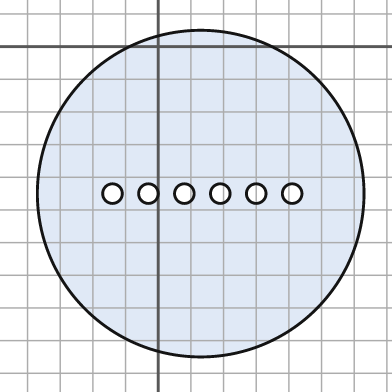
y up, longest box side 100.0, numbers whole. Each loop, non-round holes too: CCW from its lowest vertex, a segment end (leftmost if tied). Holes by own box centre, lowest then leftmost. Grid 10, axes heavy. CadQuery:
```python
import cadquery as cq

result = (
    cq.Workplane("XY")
    .moveTo(13.0, -45.0)
    .circle(50.0)
    .moveTo(-14.0, -45.0)
    .circle(3.0)
    .moveTo(-3.0, -45.0)
    .circle(3.0)
    .moveTo(8.0, -45.0)
    .circle(3.0)
    .moveTo(19.0, -45.0)
    .circle(3.0)
    .moveTo(30.0, -45.0)
    .circle(3.0)
    .moveTo(41.0, -45.0)
    .circle(3.0)
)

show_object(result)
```